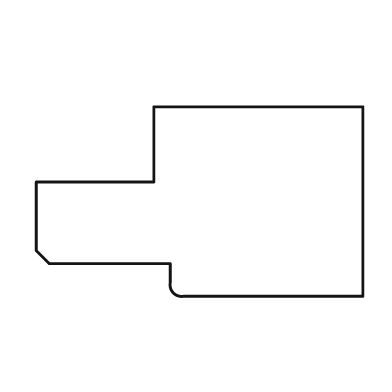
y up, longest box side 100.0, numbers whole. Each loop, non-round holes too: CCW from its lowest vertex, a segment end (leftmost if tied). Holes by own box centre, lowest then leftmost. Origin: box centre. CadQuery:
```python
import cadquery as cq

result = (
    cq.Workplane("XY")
    .moveTo(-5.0, -29.0)
    .lineTo(50.0, -29.0)
    .lineTo(50.0, 29.0)
    .lineTo(-14.0, 29.0)
    .lineTo(-14.0, 6.0)
    .lineTo(-50.0, 6.0)
    .lineTo(-50.0, -15.0)
    .lineTo(-46.0, -19.0)
    .lineTo(-9.0, -19.0)
    .lineTo(-9.0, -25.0)
    .threePointArc((-8.0, -28.0), (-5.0, -29.0))
    .close()
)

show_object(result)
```